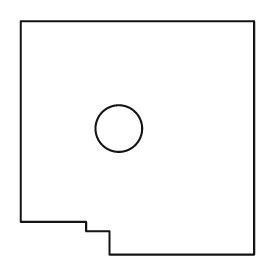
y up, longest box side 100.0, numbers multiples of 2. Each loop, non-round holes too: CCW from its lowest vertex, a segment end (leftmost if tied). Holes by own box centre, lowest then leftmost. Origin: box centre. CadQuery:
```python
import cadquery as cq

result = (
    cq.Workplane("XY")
    .moveTo(-12.0, -50.0)
    .lineTo(50.0, -50.0)
    .lineTo(50.0, 50.0)
    .lineTo(-50.0, 50.0)
    .lineTo(-50.0, -36.0)
    .lineTo(-22.0, -36.0)
    .lineTo(-22.0, -40.0)
    .lineTo(-12.0, -40.0)
    .close()
    .moveTo(-8.0, 4.0)
    .circle(10.0)
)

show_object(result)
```